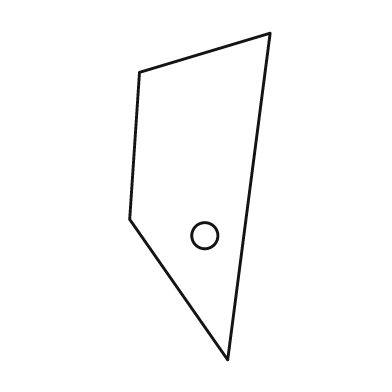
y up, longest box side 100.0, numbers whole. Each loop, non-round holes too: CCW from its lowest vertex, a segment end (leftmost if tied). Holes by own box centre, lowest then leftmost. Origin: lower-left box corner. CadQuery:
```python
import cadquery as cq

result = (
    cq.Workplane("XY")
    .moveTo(30.0, 0.0)
    .lineTo(43.0, 100.0)
    .lineTo(3.0, 88.0)
    .lineTo(0.0, 43.0)
    .close()
    .moveTo(23.0, 38.0)
    .circle(4.0)
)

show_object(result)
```